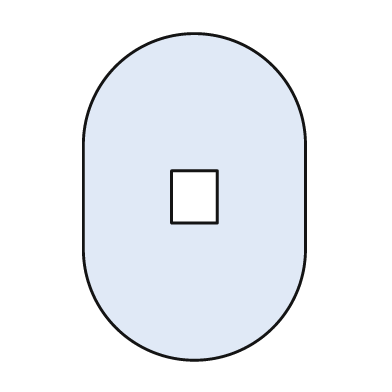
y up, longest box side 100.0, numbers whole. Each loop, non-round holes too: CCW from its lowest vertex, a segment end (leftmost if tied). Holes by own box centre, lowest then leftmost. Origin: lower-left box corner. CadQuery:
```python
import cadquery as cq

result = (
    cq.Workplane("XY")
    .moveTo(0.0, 34.0)
    .threePointArc((34.0, 0.0), (68.0, 34.0))
    .lineTo(68.0, 66.0)
    .threePointArc((34.0, 100.0), (0.0, 66.0))
    .close()
    .moveTo(27.0, 42.0)
    .lineTo(41.0, 42.0)
    .lineTo(41.0, 58.0)
    .lineTo(27.0, 58.0)
    .close()
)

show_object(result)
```